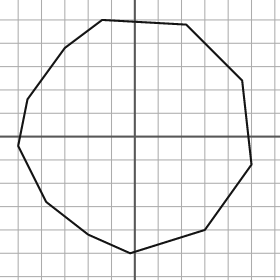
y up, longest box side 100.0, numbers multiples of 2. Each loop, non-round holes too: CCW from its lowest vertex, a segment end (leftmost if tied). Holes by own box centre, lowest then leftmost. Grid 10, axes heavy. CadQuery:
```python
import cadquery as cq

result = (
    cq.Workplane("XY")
    .moveTo(-2.0, -50.0)
    .lineTo(30.0, -40.0)
    .lineTo(50.0, -12.0)
    .lineTo(46.0, 24.0)
    .lineTo(22.0, 48.0)
    .lineTo(-14.0, 50.0)
    .lineTo(-30.0, 38.0)
    .lineTo(-46.0, 16.0)
    .lineTo(-50.0, -4.0)
    .lineTo(-38.0, -28.0)
    .lineTo(-20.0, -42.0)
    .close()
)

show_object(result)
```